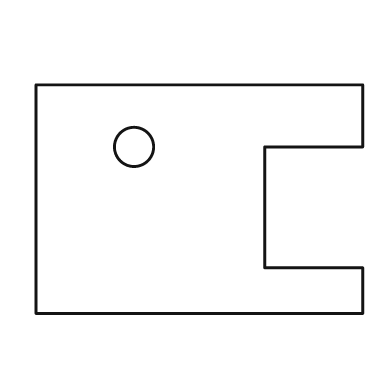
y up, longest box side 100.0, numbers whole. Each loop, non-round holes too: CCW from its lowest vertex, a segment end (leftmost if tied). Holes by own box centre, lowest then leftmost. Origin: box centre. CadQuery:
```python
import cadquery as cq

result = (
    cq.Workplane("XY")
    .moveTo(-50.0, -35.0)
    .lineTo(50.0, -35.0)
    .lineTo(50.0, -21.0)
    .lineTo(20.0, -21.0)
    .lineTo(20.0, 16.0)
    .lineTo(50.0, 16.0)
    .lineTo(50.0, 35.0)
    .lineTo(-50.0, 35.0)
    .close()
    .moveTo(-20.0, 16.0)
    .circle(6.0)
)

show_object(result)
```